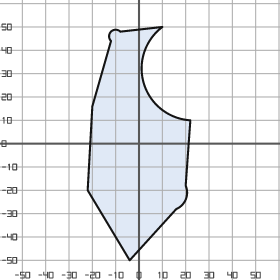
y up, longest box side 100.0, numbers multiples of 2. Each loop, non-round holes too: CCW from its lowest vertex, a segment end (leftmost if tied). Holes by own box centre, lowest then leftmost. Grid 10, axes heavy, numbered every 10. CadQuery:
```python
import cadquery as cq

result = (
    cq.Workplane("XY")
    .moveTo(-4.0, -50.0)
    .lineTo(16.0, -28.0)
    .threePointArc((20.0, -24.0), (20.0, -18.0))
    .lineTo(22.0, 10.0)
    .threePointArc((2.0, 26.0), (10.0, 50.0))
    .lineTo(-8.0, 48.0)
    .threePointArc((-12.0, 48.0), (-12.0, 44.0))
    .lineTo(-20.0, 16.0)
    .lineTo(-22.0, -20.0)
    .close()
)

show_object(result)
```